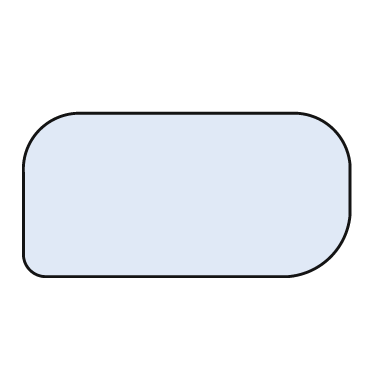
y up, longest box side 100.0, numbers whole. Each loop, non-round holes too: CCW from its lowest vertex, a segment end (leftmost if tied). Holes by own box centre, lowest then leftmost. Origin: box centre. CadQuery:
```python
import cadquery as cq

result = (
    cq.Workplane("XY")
    .moveTo(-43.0, -25.0)
    .lineTo(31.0, -25.0)
    .threePointArc((44.0, -19.0), (50.0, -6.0))
    .lineTo(50.0, 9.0)
    .threePointArc((45.0, 20.0), (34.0, 25.0))
    .lineTo(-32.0, 25.0)
    .threePointArc((-45.0, 20.0), (-50.0, 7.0))
    .lineTo(-50.0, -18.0)
    .threePointArc((-48.0, -23.0), (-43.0, -25.0))
    .close()
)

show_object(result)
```